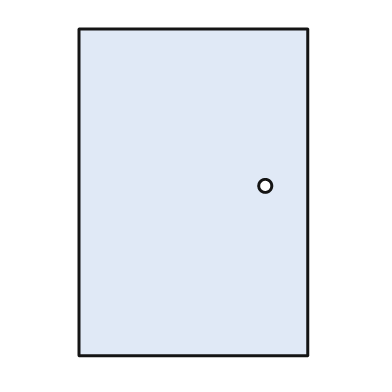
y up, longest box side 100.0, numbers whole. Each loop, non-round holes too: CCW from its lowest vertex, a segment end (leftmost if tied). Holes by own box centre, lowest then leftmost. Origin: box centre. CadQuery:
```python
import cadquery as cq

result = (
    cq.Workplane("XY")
    .moveTo(-35.0, -50.0)
    .lineTo(35.0, -50.0)
    .lineTo(35.0, 50.0)
    .lineTo(-35.0, 50.0)
    .close()
    .moveTo(22.0, 2.0)
    .circle(2.0)
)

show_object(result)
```